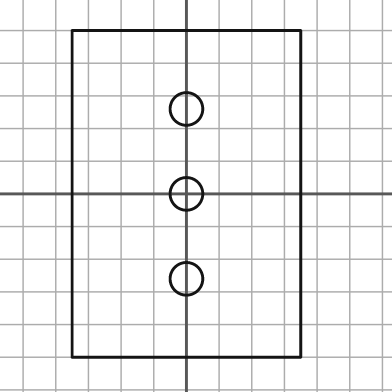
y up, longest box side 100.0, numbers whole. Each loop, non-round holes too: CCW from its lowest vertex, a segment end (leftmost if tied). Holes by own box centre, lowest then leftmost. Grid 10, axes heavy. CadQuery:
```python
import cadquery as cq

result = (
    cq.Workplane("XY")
    .moveTo(-35.0, -50.0)
    .lineTo(35.0, -50.0)
    .lineTo(35.0, 50.0)
    .lineTo(-35.0, 50.0)
    .close()
    .moveTo(0.0, -26.0)
    .circle(5.0)
    .moveTo(0.0, 0.0)
    .circle(5.0)
    .moveTo(0.0, 26.0)
    .circle(5.0)
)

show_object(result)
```